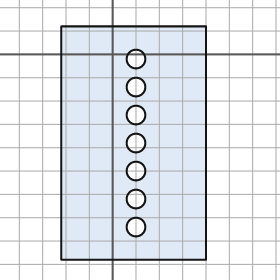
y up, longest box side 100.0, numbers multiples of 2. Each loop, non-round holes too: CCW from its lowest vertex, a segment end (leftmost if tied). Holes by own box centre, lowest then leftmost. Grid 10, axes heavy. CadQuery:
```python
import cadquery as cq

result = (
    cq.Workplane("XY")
    .moveTo(-22.0, -88.0)
    .lineTo(40.0, -88.0)
    .lineTo(40.0, 12.0)
    .lineTo(-22.0, 12.0)
    .close()
    .moveTo(10.0, -74.0)
    .circle(4.0)
    .moveTo(10.0, -62.0)
    .circle(4.0)
    .moveTo(10.0, -50.0)
    .circle(4.0)
    .moveTo(10.0, -38.0)
    .circle(4.0)
    .moveTo(10.0, -26.0)
    .circle(4.0)
    .moveTo(10.0, -14.0)
    .circle(4.0)
    .moveTo(10.0, -2.0)
    .circle(4.0)
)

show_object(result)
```